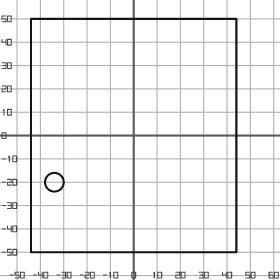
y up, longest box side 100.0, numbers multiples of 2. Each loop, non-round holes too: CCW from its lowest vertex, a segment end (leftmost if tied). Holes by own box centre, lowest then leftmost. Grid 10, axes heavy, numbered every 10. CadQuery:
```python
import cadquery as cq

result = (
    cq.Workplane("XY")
    .moveTo(-44.0, -50.0)
    .lineTo(44.0, -50.0)
    .lineTo(44.0, 50.0)
    .lineTo(-44.0, 50.0)
    .close()
    .moveTo(-34.0, -20.0)
    .circle(4.0)
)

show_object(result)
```